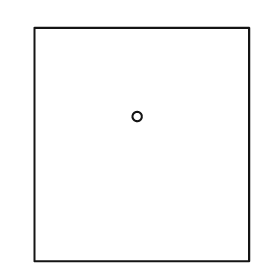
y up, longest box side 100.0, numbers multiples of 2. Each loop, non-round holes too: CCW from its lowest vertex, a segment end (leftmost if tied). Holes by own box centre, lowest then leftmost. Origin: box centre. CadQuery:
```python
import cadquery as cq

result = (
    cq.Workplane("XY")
    .moveTo(-46.0, -50.0)
    .lineTo(46.0, -50.0)
    .lineTo(46.0, 50.0)
    .lineTo(-46.0, 50.0)
    .close()
    .moveTo(-2.0, 12.0)
    .circle(2.0)
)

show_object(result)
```